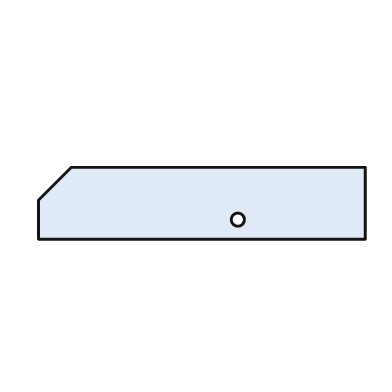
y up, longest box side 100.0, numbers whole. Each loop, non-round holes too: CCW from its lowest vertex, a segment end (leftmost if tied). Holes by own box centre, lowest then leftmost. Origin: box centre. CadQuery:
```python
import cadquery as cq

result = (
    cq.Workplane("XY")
    .moveTo(-50.0, -11.0)
    .lineTo(50.0, -11.0)
    .lineTo(50.0, 11.0)
    .lineTo(-40.0, 11.0)
    .lineTo(-50.0, 1.0)
    .close()
    .moveTo(11.0, -5.0)
    .circle(2.0)
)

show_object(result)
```